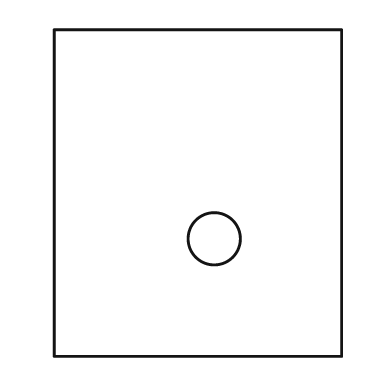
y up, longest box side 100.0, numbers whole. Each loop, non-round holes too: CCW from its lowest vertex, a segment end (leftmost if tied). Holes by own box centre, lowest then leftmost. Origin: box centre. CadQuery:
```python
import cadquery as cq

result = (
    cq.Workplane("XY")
    .moveTo(-44.0, -50.0)
    .lineTo(44.0, -50.0)
    .lineTo(44.0, 50.0)
    .lineTo(-44.0, 50.0)
    .close()
    .moveTo(5.0, -14.0)
    .circle(8.0)
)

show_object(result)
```